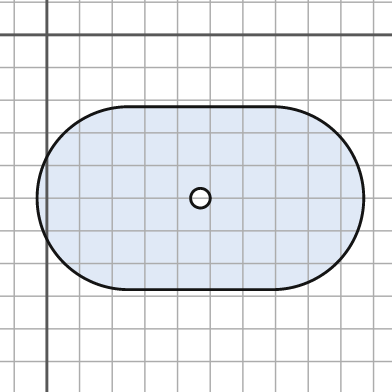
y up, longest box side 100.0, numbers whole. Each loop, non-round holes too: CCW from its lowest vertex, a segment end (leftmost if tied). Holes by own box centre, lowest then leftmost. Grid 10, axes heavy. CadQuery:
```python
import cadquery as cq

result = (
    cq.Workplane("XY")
    .moveTo(25.0, -78.0)
    .lineTo(69.0, -78.0)
    .threePointArc((97.0, -50.0), (69.0, -22.0))
    .lineTo(25.0, -22.0)
    .threePointArc((-3.0, -50.0), (25.0, -78.0))
    .close()
    .moveTo(47.0, -50.0)
    .circle(3.0)
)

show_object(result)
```